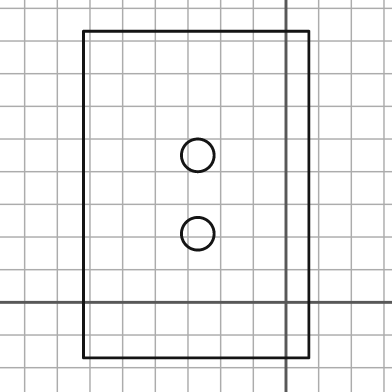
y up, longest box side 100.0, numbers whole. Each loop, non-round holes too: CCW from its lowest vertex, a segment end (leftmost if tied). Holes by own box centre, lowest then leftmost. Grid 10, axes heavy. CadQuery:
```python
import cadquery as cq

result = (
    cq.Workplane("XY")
    .moveTo(-62.0, -17.0)
    .lineTo(7.0, -17.0)
    .lineTo(7.0, 83.0)
    .lineTo(-62.0, 83.0)
    .close()
    .moveTo(-27.0, 21.0)
    .circle(5.0)
    .moveTo(-27.0, 45.0)
    .circle(5.0)
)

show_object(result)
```